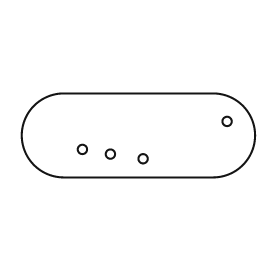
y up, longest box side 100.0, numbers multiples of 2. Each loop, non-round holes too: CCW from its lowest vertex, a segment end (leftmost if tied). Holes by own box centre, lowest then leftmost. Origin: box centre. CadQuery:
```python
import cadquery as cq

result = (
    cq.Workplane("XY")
    .moveTo(-32.0, -18.0)
    .lineTo(32.0, -18.0)
    .threePointArc((50.0, 0.0), (32.0, 18.0))
    .lineTo(-32.0, 18.0)
    .threePointArc((-50.0, 0.0), (-32.0, -18.0))
    .close()
    .moveTo(2.0, -10.0)
    .circle(2.0)
    .moveTo(-12.0, -8.0)
    .circle(2.0)
    .moveTo(-24.0, -6.0)
    .circle(2.0)
    .moveTo(38.0, 6.0)
    .circle(2.0)
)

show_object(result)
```